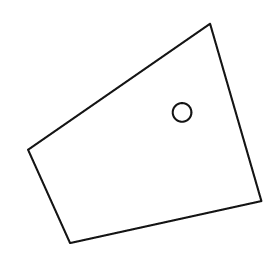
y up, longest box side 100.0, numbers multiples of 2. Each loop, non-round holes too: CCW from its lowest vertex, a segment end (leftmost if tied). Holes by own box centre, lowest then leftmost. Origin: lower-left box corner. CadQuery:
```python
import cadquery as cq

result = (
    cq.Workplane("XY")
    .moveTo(18.0, 0.0)
    .lineTo(100.0, 18.0)
    .lineTo(78.0, 94.0)
    .lineTo(0.0, 40.0)
    .close()
    .moveTo(66.0, 56.0)
    .circle(4.0)
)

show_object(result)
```